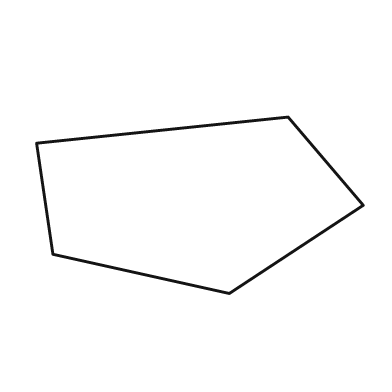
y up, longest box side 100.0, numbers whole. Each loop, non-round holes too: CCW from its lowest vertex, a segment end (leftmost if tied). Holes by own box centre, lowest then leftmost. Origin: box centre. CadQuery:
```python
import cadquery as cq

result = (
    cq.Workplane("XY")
    .moveTo(9.0, -27.0)
    .lineTo(50.0, 0.0)
    .lineTo(27.0, 27.0)
    .lineTo(-50.0, 19.0)
    .lineTo(-45.0, -15.0)
    .close()
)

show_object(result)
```